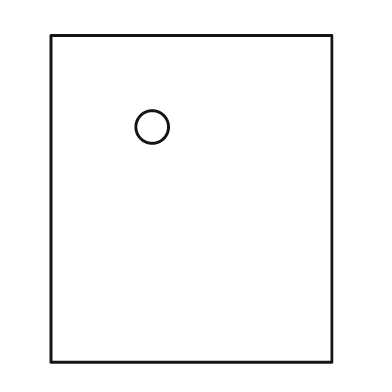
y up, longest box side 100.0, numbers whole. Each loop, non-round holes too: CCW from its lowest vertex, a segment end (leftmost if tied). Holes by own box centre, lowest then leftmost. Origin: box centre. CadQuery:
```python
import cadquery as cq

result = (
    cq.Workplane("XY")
    .moveTo(-43.0, -50.0)
    .lineTo(43.0, -50.0)
    .lineTo(43.0, 50.0)
    .lineTo(-43.0, 50.0)
    .close()
    .moveTo(-12.0, 22.0)
    .circle(5.0)
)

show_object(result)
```